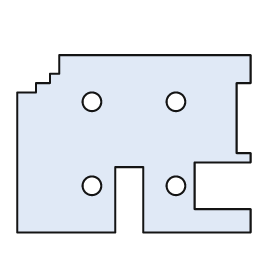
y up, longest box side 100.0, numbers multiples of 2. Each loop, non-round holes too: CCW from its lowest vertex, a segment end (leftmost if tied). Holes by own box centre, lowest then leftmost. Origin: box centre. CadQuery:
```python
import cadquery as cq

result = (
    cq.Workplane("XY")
    .moveTo(-50.0, -38.0)
    .lineTo(-8.0, -38.0)
    .lineTo(-8.0, -10.0)
    .lineTo(4.0, -10.0)
    .lineTo(4.0, -38.0)
    .lineTo(50.0, -38.0)
    .lineTo(50.0, -28.0)
    .lineTo(26.0, -28.0)
    .lineTo(26.0, -8.0)
    .lineTo(50.0, -8.0)
    .lineTo(50.0, -4.0)
    .lineTo(44.0, -4.0)
    .lineTo(44.0, 26.0)
    .lineTo(50.0, 26.0)
    .lineTo(50.0, 38.0)
    .lineTo(-32.0, 38.0)
    .lineTo(-32.0, 30.0)
    .lineTo(-36.0, 30.0)
    .lineTo(-36.0, 26.0)
    .lineTo(-42.0, 26.0)
    .lineTo(-42.0, 22.0)
    .lineTo(-50.0, 22.0)
    .close()
    .moveTo(-18.0, -18.0)
    .circle(4.0)
    .moveTo(18.0, -18.0)
    .circle(4.0)
    .moveTo(-18.0, 18.0)
    .circle(4.0)
    .moveTo(18.0, 18.0)
    .circle(4.0)
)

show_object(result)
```